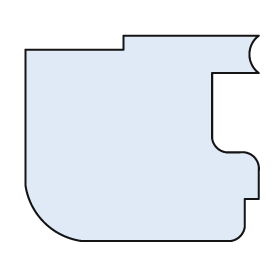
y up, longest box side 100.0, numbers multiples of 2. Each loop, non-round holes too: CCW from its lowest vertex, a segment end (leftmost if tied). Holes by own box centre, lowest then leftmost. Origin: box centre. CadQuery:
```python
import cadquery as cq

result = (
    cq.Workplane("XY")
    .moveTo(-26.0, -44.0)
    .lineTo(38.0, -44.0)
    .threePointArc((42.0, -42.0), (44.0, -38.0))
    .lineTo(44.0, -26.0)
    .lineTo(50.0, -26.0)
    .lineTo(50.0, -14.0)
    .threePointArc((48.0, -8.0), (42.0, -6.0))
    .lineTo(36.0, -6.0)
    .threePointArc((32.0, -4.0), (30.0, 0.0))
    .lineTo(30.0, 28.0)
    .lineTo(50.0, 28.0)
    .threePointArc((46.0, 36.0), (50.0, 44.0))
    .lineTo(-8.0, 44.0)
    .lineTo(-8.0, 38.0)
    .lineTo(-50.0, 38.0)
    .lineTo(-50.0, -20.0)
    .threePointArc((-42.0, -36.0), (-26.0, -44.0))
    .close()
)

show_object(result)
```